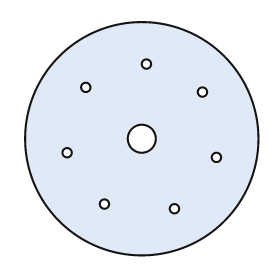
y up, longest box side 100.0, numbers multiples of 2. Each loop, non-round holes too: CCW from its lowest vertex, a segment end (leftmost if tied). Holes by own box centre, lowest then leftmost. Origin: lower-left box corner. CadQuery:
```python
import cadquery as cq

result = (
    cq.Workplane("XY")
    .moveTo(50.0, 50.0)
    .circle(50.0)
    .moveTo(64.0, 20.0)
    .circle(2.0)
    .moveTo(34.0, 22.0)
    .circle(2.0)
    .moveTo(82.0, 42.0)
    .circle(2.0)
    .moveTo(18.0, 44.0)
    .circle(2.0)
    .moveTo(50.0, 50.0)
    .circle(6.0)
    .moveTo(76.0, 70.0)
    .circle(2.0)
    .moveTo(26.0, 72.0)
    .circle(2.0)
    .moveTo(52.0, 82.0)
    .circle(2.0)
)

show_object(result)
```